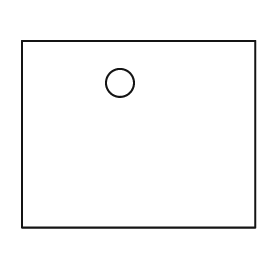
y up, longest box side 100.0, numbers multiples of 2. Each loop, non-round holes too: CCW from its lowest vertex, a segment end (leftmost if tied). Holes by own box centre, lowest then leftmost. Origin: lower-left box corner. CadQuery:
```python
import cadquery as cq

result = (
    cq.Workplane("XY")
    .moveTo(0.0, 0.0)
    .lineTo(100.0, 0.0)
    .lineTo(100.0, 80.0)
    .lineTo(0.0, 80.0)
    .close()
    .moveTo(42.0, 62.0)
    .circle(6.0)
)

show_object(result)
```